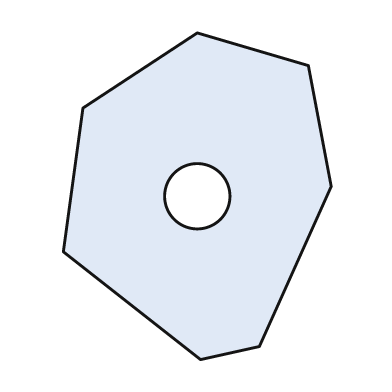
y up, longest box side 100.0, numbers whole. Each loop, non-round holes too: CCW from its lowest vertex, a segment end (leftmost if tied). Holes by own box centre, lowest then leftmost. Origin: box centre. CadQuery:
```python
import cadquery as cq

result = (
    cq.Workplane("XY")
    .moveTo(1.0, -50.0)
    .lineTo(19.0, -46.0)
    .lineTo(41.0, 3.0)
    .lineTo(34.0, 40.0)
    .lineTo(0.0, 50.0)
    .lineTo(-35.0, 27.0)
    .lineTo(-41.0, -17.0)
    .close()
    .moveTo(0.0, 0.0)
    .circle(10.0)
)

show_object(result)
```